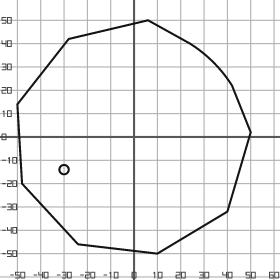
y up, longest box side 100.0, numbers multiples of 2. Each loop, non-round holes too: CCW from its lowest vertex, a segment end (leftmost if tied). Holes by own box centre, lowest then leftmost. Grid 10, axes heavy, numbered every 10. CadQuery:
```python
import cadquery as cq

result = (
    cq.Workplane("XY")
    .moveTo(10.0, -50.0)
    .lineTo(40.0, -32.0)
    .lineTo(50.0, 2.0)
    .lineTo(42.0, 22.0)
    .threePointArc((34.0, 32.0), (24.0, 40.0))
    .lineTo(6.0, 50.0)
    .lineTo(-28.0, 42.0)
    .lineTo(-50.0, 14.0)
    .lineTo(-48.0, -20.0)
    .lineTo(-24.0, -46.0)
    .close()
    .moveTo(-30.0, -14.0)
    .circle(2.0)
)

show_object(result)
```